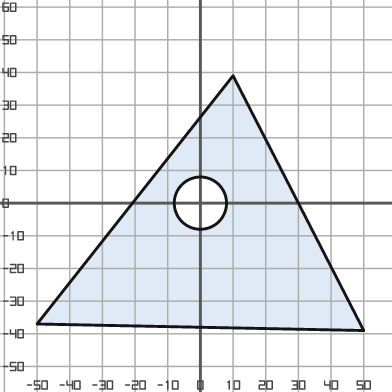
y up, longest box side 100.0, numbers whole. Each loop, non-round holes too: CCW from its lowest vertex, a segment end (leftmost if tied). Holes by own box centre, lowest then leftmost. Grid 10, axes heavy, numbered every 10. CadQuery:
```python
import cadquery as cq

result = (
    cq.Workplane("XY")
    .moveTo(50.0, -39.0)
    .lineTo(10.0, 39.0)
    .lineTo(-50.0, -37.0)
    .close()
    .moveTo(0.0, 0.0)
    .circle(8.0)
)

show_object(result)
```